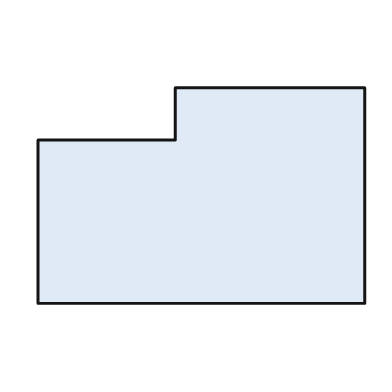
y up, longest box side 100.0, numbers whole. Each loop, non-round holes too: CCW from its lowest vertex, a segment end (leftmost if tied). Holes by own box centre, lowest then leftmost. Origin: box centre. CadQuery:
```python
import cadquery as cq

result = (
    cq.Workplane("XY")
    .moveTo(-50.0, -33.0)
    .lineTo(50.0, -33.0)
    .lineTo(50.0, 33.0)
    .lineTo(-8.0, 33.0)
    .lineTo(-8.0, 17.0)
    .lineTo(-50.0, 17.0)
    .close()
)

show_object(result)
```